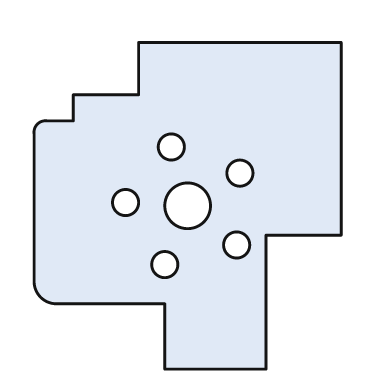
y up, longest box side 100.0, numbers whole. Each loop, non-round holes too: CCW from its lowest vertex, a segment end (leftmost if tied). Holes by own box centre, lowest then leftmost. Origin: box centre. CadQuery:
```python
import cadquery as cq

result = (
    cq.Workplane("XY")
    .moveTo(-7.0, -50.0)
    .lineTo(24.0, -50.0)
    .lineTo(24.0, -9.0)
    .lineTo(47.0, -9.0)
    .lineTo(47.0, 50.0)
    .lineTo(-15.0, 50.0)
    .lineTo(-15.0, 34.0)
    .lineTo(-35.0, 34.0)
    .lineTo(-35.0, 26.0)
    .lineTo(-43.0, 26.0)
    .threePointArc((-46.0, 25.0), (-47.0, 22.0))
    .lineTo(-47.0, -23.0)
    .threePointArc((-45.0, -28.0), (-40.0, -30.0))
    .lineTo(-7.0, -30.0)
    .close()
    .moveTo(-7.0, -18.0)
    .circle(4.0)
    .moveTo(15.0, -12.0)
    .circle(4.0)
    .moveTo(0.0, 0.0)
    .circle(7.0)
    .moveTo(-19.0, 1.0)
    .circle(4.0)
    .moveTo(16.0, 10.0)
    .circle(4.0)
    .moveTo(-5.0, 18.0)
    .circle(4.0)
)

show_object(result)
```